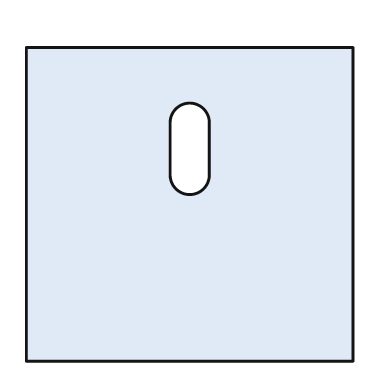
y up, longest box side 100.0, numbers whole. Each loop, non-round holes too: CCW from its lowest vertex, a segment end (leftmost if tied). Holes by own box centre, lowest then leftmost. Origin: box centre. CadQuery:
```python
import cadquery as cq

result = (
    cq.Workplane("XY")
    .moveTo(-50.0, -48.0)
    .lineTo(50.0, -48.0)
    .lineTo(50.0, 48.0)
    .lineTo(-50.0, 48.0)
    .close()
    .moveTo(-6.0, 9.0)
    .threePointArc((0.0, 3.0), (6.0, 9.0))
    .lineTo(6.0, 25.0)
    .threePointArc((0.0, 31.0), (-6.0, 25.0))
    .close()
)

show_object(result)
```